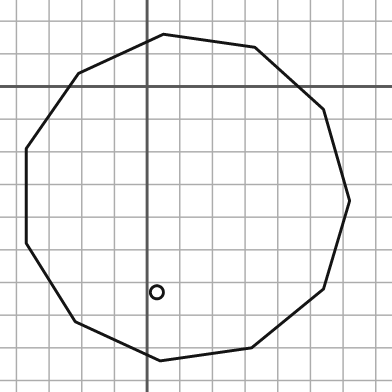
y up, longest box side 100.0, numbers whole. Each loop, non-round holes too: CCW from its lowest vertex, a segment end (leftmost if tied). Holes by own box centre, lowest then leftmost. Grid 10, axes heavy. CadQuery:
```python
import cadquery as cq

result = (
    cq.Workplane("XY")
    .moveTo(4.0, -84.0)
    .lineTo(32.0, -80.0)
    .lineTo(54.0, -62.0)
    .lineTo(62.0, -35.0)
    .lineTo(54.0, -7.0)
    .lineTo(33.0, 12.0)
    .lineTo(5.0, 16.0)
    .lineTo(-21.0, 4.0)
    .lineTo(-37.0, -19.0)
    .lineTo(-37.0, -48.0)
    .lineTo(-22.0, -72.0)
    .close()
    .moveTo(3.0, -63.0)
    .circle(2.0)
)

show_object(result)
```